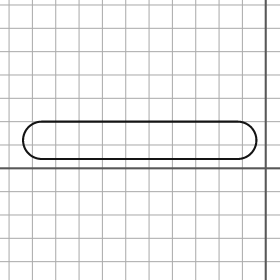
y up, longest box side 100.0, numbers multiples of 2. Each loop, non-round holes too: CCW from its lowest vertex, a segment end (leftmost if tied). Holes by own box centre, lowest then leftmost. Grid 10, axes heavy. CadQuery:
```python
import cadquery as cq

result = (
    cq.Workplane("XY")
    .moveTo(-96.0, 4.0)
    .lineTo(-12.0, 4.0)
    .threePointArc((-4.0, 12.0), (-12.0, 20.0))
    .lineTo(-96.0, 20.0)
    .threePointArc((-104.0, 12.0), (-96.0, 4.0))
    .close()
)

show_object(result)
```